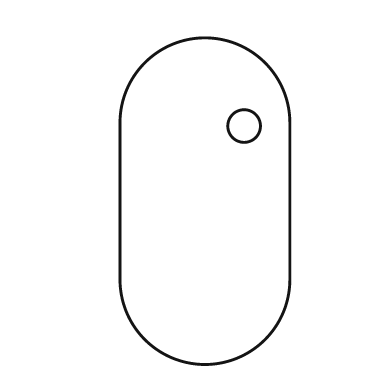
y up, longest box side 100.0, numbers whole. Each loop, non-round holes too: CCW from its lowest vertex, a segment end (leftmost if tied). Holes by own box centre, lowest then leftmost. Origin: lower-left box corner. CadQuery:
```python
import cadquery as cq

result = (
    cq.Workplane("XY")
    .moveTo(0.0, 26.0)
    .threePointArc((26.0, 0.0), (52.0, 26.0))
    .lineTo(52.0, 74.0)
    .threePointArc((26.0, 100.0), (0.0, 74.0))
    .close()
    .moveTo(38.0, 73.0)
    .circle(5.0)
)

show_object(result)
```